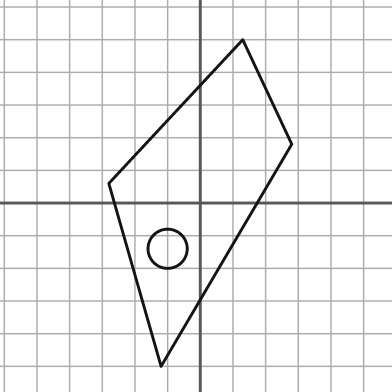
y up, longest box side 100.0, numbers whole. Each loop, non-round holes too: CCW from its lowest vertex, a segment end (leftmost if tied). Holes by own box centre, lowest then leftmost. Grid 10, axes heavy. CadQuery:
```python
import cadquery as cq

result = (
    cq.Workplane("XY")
    .moveTo(-12.0, -50.0)
    .lineTo(28.0, 18.0)
    .lineTo(13.0, 50.0)
    .lineTo(-28.0, 6.0)
    .close()
    .moveTo(-10.0, -14.0)
    .circle(6.0)
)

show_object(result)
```